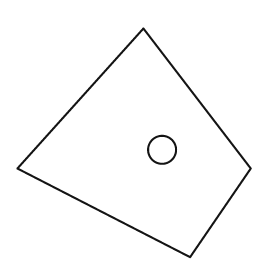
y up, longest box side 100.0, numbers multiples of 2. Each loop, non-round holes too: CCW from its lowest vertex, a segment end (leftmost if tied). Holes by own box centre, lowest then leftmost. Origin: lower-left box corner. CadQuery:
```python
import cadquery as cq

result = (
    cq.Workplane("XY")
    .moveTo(74.0, 0.0)
    .lineTo(100.0, 38.0)
    .lineTo(54.0, 98.0)
    .lineTo(0.0, 38.0)
    .close()
    .moveTo(62.0, 46.0)
    .circle(6.0)
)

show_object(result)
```